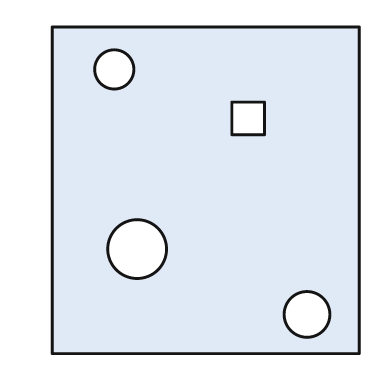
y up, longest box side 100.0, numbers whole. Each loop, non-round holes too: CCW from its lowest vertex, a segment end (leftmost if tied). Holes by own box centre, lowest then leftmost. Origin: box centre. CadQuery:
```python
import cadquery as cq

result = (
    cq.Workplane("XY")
    .moveTo(-47.0, -50.0)
    .lineTo(47.0, -50.0)
    .lineTo(47.0, 50.0)
    .lineTo(-47.0, 50.0)
    .close()
    .moveTo(31.0, -38.0)
    .circle(7.0)
    .moveTo(-21.0, -18.0)
    .circle(9.0)
    .moveTo(8.0, 17.0)
    .lineTo(18.0, 17.0)
    .lineTo(18.0, 27.0)
    .lineTo(8.0, 27.0)
    .close()
    .moveTo(-28.0, 37.0)
    .circle(6.0)
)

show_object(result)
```